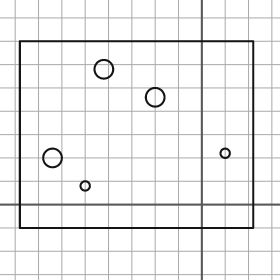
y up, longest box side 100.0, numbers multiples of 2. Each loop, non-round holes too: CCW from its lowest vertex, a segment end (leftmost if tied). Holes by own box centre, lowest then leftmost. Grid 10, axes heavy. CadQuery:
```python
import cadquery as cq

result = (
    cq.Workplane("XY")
    .moveTo(-78.0, -10.0)
    .lineTo(22.0, -10.0)
    .lineTo(22.0, 70.0)
    .lineTo(-78.0, 70.0)
    .close()
    .moveTo(-50.0, 8.0)
    .circle(2.0)
    .moveTo(-64.0, 20.0)
    .circle(4.0)
    .moveTo(10.0, 22.0)
    .circle(2.0)
    .moveTo(-20.0, 46.0)
    .circle(4.0)
    .moveTo(-42.0, 58.0)
    .circle(4.0)
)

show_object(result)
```